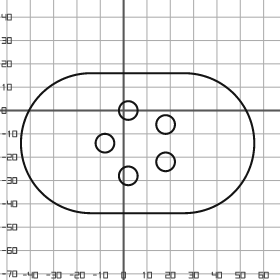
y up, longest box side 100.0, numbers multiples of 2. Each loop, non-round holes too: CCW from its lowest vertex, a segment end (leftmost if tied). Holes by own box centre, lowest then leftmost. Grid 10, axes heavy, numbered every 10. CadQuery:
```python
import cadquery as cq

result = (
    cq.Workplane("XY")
    .moveTo(-14.0, -44.0)
    .lineTo(26.0, -44.0)
    .threePointArc((56.0, -14.0), (26.0, 16.0))
    .lineTo(-14.0, 16.0)
    .threePointArc((-44.0, -14.0), (-14.0, -44.0))
    .close()
    .moveTo(2.0, -28.0)
    .circle(4.0)
    .moveTo(18.0, -22.0)
    .circle(4.0)
    .moveTo(-8.0, -14.0)
    .circle(4.0)
    .moveTo(18.0, -6.0)
    .circle(4.0)
    .moveTo(2.0, 0.0)
    .circle(4.0)
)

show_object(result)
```